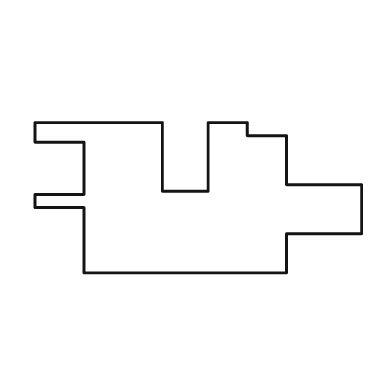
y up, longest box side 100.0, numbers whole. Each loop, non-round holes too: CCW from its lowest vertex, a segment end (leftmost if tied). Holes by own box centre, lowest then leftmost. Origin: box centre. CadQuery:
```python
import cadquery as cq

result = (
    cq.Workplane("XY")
    .moveTo(-35.0, -23.0)
    .lineTo(27.0, -23.0)
    .lineTo(27.0, -11.0)
    .lineTo(50.0, -11.0)
    .lineTo(50.0, 4.0)
    .lineTo(27.0, 4.0)
    .lineTo(27.0, 19.0)
    .lineTo(15.0, 19.0)
    .lineTo(15.0, 23.0)
    .lineTo(3.0, 23.0)
    .lineTo(3.0, 2.0)
    .lineTo(-11.0, 2.0)
    .lineTo(-11.0, 23.0)
    .lineTo(-50.0, 23.0)
    .lineTo(-50.0, 17.0)
    .lineTo(-35.0, 17.0)
    .lineTo(-35.0, 1.0)
    .lineTo(-50.0, 1.0)
    .lineTo(-50.0, -3.0)
    .lineTo(-35.0, -3.0)
    .close()
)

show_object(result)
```